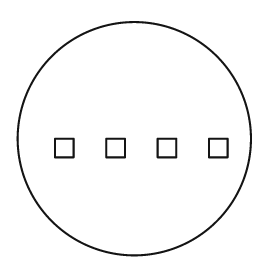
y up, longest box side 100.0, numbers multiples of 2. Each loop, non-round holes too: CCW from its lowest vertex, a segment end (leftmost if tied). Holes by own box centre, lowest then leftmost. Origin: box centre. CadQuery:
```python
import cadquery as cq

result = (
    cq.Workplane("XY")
    .moveTo(0.0, 0.0)
    .circle(50.0)
    .moveTo(-34.0, -8.0)
    .lineTo(-26.0, -8.0)
    .lineTo(-26.0, 0.0)
    .lineTo(-34.0, 0.0)
    .close()
    .moveTo(-12.0, -8.0)
    .lineTo(-4.0, -8.0)
    .lineTo(-4.0, 0.0)
    .lineTo(-12.0, 0.0)
    .close()
    .moveTo(10.0, -8.0)
    .lineTo(18.0, -8.0)
    .lineTo(18.0, 0.0)
    .lineTo(10.0, 0.0)
    .close()
    .moveTo(32.0, -8.0)
    .lineTo(40.0, -8.0)
    .lineTo(40.0, 0.0)
    .lineTo(32.0, 0.0)
    .close()
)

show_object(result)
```